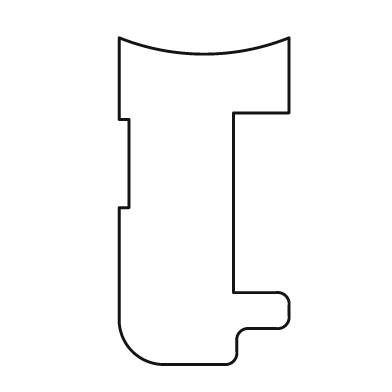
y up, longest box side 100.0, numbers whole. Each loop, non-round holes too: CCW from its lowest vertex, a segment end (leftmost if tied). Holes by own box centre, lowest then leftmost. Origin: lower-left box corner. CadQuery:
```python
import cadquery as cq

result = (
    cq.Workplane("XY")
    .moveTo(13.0, 0.0)
    .lineTo(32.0, 0.0)
    .threePointArc((35.0, 1.0), (36.0, 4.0))
    .lineTo(36.0, 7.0)
    .threePointArc((37.0, 10.0), (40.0, 11.0))
    .lineTo(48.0, 11.0)
    .threePointArc((51.0, 12.0), (52.0, 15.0))
    .lineTo(52.0, 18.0)
    .threePointArc((51.0, 21.0), (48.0, 22.0))
    .lineTo(35.0, 22.0)
    .lineTo(35.0, 77.0)
    .lineTo(52.0, 77.0)
    .lineTo(52.0, 100.0)
    .threePointArc((26.0, 95.0), (0.0, 100.0))
    .lineTo(0.0, 75.0)
    .lineTo(3.0, 75.0)
    .lineTo(3.0, 48.0)
    .lineTo(0.0, 48.0)
    .lineTo(0.0, 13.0)
    .threePointArc((4.0, 4.0), (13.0, 0.0))
    .close()
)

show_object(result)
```